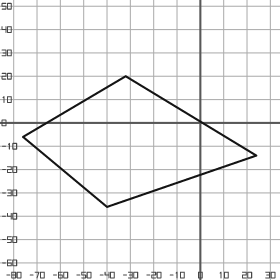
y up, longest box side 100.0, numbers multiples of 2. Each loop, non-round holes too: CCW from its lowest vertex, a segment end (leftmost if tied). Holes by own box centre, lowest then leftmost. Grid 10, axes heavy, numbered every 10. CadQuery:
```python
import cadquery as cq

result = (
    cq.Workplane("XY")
    .moveTo(-40.0, -36.0)
    .lineTo(24.0, -14.0)
    .lineTo(-32.0, 20.0)
    .lineTo(-76.0, -6.0)
    .close()
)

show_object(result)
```